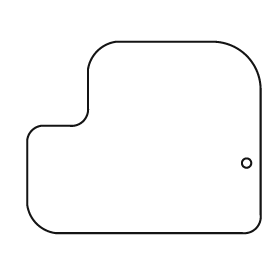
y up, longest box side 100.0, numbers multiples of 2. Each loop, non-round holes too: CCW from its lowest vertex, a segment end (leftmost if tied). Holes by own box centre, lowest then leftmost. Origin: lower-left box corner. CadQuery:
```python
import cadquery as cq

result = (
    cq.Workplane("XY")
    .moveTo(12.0, 0.0)
    .lineTo(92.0, 0.0)
    .threePointArc((98.0, 2.0), (100.0, 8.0))
    .lineTo(100.0, 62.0)
    .threePointArc((94.0, 76.0), (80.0, 82.0))
    .lineTo(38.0, 82.0)
    .threePointArc((30.0, 78.0), (26.0, 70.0))
    .lineTo(26.0, 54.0)
    .threePointArc((24.0, 48.0), (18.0, 46.0))
    .lineTo(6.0, 46.0)
    .threePointArc((2.0, 44.0), (0.0, 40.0))
    .lineTo(0.0, 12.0)
    .threePointArc((4.0, 4.0), (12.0, 0.0))
    .close()
    .moveTo(94.0, 30.0)
    .circle(2.0)
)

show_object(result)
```